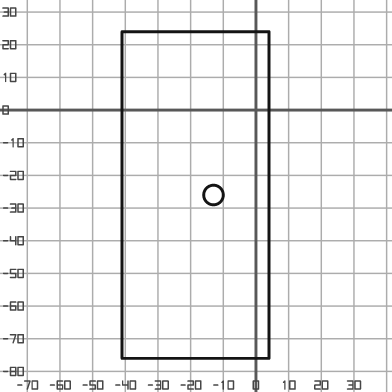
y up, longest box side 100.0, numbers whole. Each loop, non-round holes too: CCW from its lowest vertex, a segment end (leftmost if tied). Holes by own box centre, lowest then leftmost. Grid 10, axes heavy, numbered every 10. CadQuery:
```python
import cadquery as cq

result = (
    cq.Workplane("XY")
    .moveTo(-41.0, -76.0)
    .lineTo(4.0, -76.0)
    .lineTo(4.0, 24.0)
    .lineTo(-41.0, 24.0)
    .close()
    .moveTo(-13.0, -26.0)
    .circle(3.0)
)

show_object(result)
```